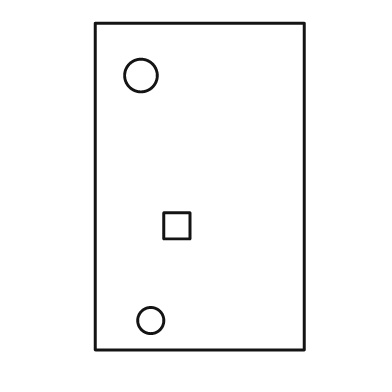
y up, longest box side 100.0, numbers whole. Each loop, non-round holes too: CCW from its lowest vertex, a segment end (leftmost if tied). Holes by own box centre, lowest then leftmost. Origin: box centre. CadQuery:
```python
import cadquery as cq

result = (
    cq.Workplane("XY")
    .moveTo(-32.0, -50.0)
    .lineTo(32.0, -50.0)
    .lineTo(32.0, 50.0)
    .lineTo(-32.0, 50.0)
    .close()
    .moveTo(-15.0, -41.0)
    .circle(4.0)
    .moveTo(-11.0, -16.0)
    .lineTo(-3.0, -16.0)
    .lineTo(-3.0, -8.0)
    .lineTo(-11.0, -8.0)
    .close()
    .moveTo(-18.0, 34.0)
    .circle(5.0)
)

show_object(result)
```